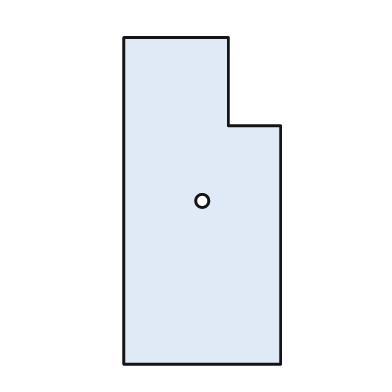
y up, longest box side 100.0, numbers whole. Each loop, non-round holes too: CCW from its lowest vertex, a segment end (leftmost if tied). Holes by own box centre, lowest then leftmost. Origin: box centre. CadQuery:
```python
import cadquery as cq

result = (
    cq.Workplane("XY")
    .moveTo(-24.0, -50.0)
    .lineTo(24.0, -50.0)
    .lineTo(24.0, 23.0)
    .lineTo(8.0, 23.0)
    .lineTo(8.0, 50.0)
    .lineTo(-24.0, 50.0)
    .close()
    .moveTo(0.0, 0.0)
    .circle(2.0)
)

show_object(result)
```